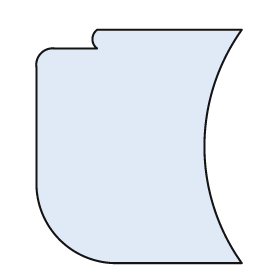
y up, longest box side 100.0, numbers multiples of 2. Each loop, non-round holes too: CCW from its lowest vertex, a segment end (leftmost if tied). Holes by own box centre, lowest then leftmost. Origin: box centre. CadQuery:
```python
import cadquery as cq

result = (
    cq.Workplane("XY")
    .moveTo(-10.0, -50.0)
    .lineTo(44.0, -50.0)
    .threePointArc((28.0, 0.0), (44.0, 50.0))
    .lineTo(-18.0, 50.0)
    .threePointArc((-20.0, 46.0), (-18.0, 42.0))
    .lineTo(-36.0, 42.0)
    .threePointArc((-42.0, 40.0), (-44.0, 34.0))
    .lineTo(-44.0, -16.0)
    .threePointArc((-34.0, -40.0), (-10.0, -50.0))
    .close()
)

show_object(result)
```